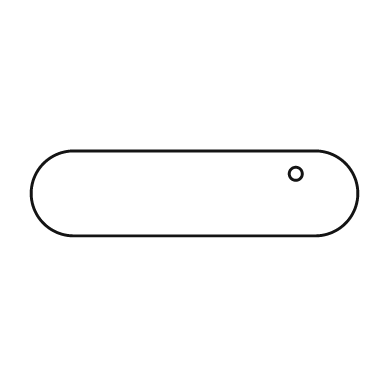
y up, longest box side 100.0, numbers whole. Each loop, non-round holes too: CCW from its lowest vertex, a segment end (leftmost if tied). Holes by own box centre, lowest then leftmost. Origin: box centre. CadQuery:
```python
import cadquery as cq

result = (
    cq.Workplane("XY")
    .moveTo(-37.0, -13.0)
    .lineTo(37.0, -13.0)
    .threePointArc((50.0, 0.0), (37.0, 13.0))
    .lineTo(-37.0, 13.0)
    .threePointArc((-50.0, 0.0), (-37.0, -13.0))
    .close()
    .moveTo(31.0, 6.0)
    .circle(2.0)
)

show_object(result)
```